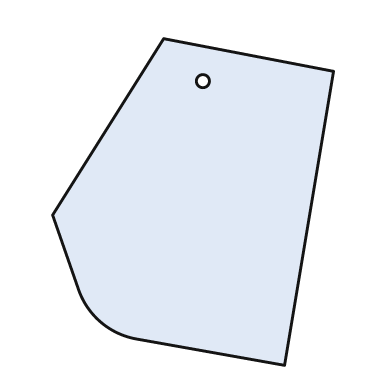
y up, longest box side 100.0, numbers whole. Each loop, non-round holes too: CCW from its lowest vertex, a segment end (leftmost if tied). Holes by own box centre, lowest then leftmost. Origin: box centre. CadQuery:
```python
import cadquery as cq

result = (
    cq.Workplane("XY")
    .moveTo(28.0, -50.0)
    .lineTo(43.0, 40.0)
    .lineTo(-9.0, 50.0)
    .lineTo(-43.0, -4.0)
    .lineTo(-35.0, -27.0)
    .threePointArc((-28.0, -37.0), (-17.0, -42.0))
    .close()
    .moveTo(3.0, 37.0)
    .circle(2.0)
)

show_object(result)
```